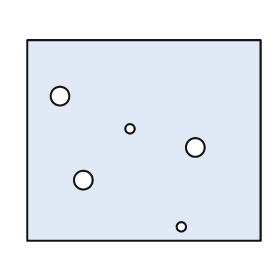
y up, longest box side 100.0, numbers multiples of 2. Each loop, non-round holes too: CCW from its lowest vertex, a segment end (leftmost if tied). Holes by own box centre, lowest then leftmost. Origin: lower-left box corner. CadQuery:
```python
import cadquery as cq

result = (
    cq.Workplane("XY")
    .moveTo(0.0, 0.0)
    .lineTo(100.0, 0.0)
    .lineTo(100.0, 86.0)
    .lineTo(0.0, 86.0)
    .close()
    .moveTo(66.0, 6.0)
    .circle(2.0)
    .moveTo(24.0, 26.0)
    .circle(4.0)
    .moveTo(72.0, 40.0)
    .circle(4.0)
    .moveTo(44.0, 48.0)
    .circle(2.0)
    .moveTo(14.0, 62.0)
    .circle(4.0)
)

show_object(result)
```